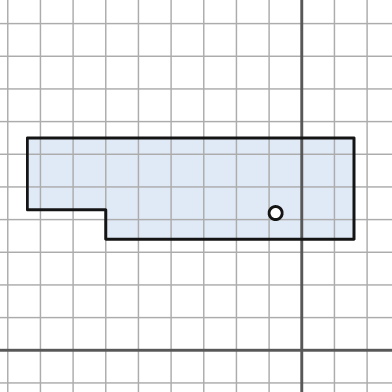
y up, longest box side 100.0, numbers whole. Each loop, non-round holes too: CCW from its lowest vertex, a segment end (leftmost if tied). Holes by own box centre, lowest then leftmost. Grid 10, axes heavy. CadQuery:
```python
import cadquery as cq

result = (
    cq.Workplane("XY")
    .moveTo(-60.0, 34.0)
    .lineTo(16.0, 34.0)
    .lineTo(16.0, 65.0)
    .lineTo(-84.0, 65.0)
    .lineTo(-84.0, 43.0)
    .lineTo(-60.0, 43.0)
    .close()
    .moveTo(-8.0, 42.0)
    .circle(2.0)
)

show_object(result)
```